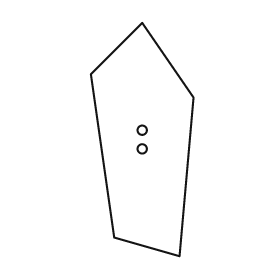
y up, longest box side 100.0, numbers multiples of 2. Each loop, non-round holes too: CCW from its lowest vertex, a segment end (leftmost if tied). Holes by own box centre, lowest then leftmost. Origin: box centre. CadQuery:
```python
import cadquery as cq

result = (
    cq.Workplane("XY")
    .moveTo(16.0, -50.0)
    .lineTo(22.0, 18.0)
    .lineTo(0.0, 50.0)
    .lineTo(-22.0, 28.0)
    .lineTo(-12.0, -42.0)
    .close()
    .moveTo(0.0, -4.0)
    .circle(2.0)
    .moveTo(0.0, 4.0)
    .circle(2.0)
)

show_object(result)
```